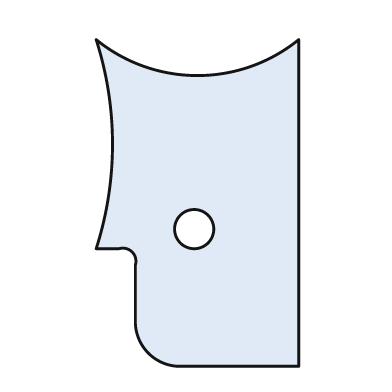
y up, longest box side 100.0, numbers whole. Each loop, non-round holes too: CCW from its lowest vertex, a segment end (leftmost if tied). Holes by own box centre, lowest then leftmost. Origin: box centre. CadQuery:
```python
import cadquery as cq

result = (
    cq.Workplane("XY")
    .moveTo(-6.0, -50.0)
    .lineTo(31.0, -50.0)
    .lineTo(31.0, 50.0)
    .threePointArc((0.0, 39.0), (-31.0, 50.0))
    .threePointArc((-26.0, 18.0), (-31.0, -14.0))
    .lineTo(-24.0, -14.0)
    .threePointArc((-20.0, -15.0), (-19.0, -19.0))
    .lineTo(-19.0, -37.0)
    .threePointArc((-15.0, -46.0), (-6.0, -50.0))
    .close()
    .moveTo(-1.0, -8.0)
    .circle(6.0)
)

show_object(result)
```